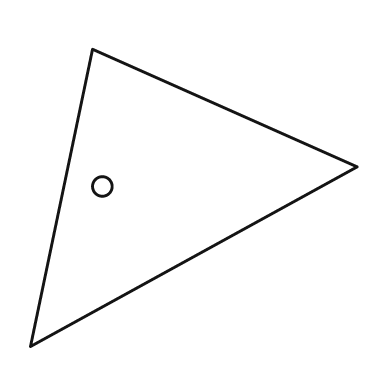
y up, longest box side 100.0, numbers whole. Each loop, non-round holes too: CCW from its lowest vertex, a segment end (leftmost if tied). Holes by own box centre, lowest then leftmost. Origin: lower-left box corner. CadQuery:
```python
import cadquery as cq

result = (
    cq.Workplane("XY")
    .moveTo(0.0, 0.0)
    .lineTo(100.0, 55.0)
    .lineTo(19.0, 91.0)
    .close()
    .moveTo(22.0, 49.0)
    .circle(3.0)
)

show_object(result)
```